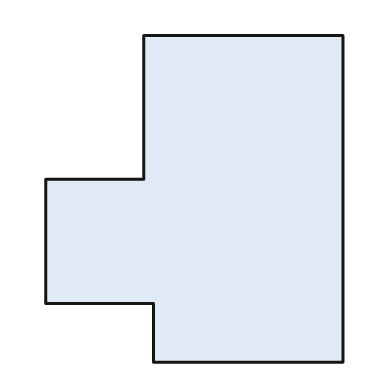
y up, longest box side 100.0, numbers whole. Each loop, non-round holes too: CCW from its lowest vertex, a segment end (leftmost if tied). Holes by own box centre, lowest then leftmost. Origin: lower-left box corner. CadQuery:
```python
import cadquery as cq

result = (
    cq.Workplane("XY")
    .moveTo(33.0, 0.0)
    .lineTo(91.0, 0.0)
    .lineTo(91.0, 100.0)
    .lineTo(30.0, 100.0)
    .lineTo(30.0, 56.0)
    .lineTo(0.0, 56.0)
    .lineTo(0.0, 18.0)
    .lineTo(33.0, 18.0)
    .close()
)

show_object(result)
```